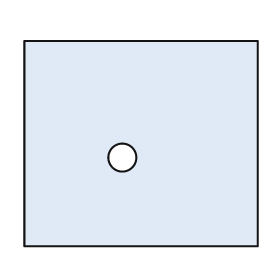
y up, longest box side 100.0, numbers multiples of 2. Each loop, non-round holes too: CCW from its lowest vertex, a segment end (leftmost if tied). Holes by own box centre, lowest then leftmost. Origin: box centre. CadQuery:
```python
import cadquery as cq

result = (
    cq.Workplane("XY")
    .moveTo(-50.0, -44.0)
    .lineTo(50.0, -44.0)
    .lineTo(50.0, 44.0)
    .lineTo(-50.0, 44.0)
    .close()
    .moveTo(-8.0, -6.0)
    .circle(6.0)
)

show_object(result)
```